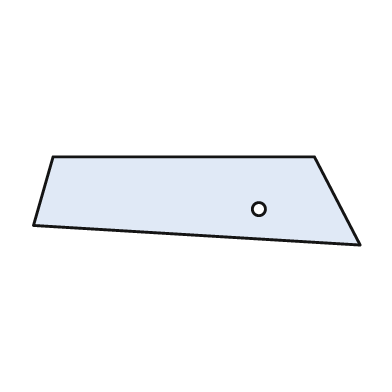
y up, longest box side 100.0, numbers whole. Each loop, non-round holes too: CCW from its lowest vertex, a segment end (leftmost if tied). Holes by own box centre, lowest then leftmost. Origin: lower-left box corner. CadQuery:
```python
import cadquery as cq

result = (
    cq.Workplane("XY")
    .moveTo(100.0, 0.0)
    .lineTo(86.0, 27.0)
    .lineTo(6.0, 27.0)
    .lineTo(0.0, 6.0)
    .close()
    .moveTo(69.0, 11.0)
    .circle(2.0)
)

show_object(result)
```